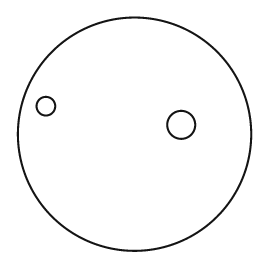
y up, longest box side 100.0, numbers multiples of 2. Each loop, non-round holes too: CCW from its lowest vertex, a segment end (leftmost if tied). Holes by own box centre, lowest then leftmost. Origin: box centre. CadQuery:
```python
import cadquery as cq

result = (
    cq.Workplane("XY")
    .moveTo(0.0, 0.0)
    .circle(50.0)
    .moveTo(20.0, 4.0)
    .circle(6.0)
    .moveTo(-38.0, 12.0)
    .circle(4.0)
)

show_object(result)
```